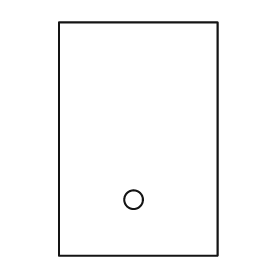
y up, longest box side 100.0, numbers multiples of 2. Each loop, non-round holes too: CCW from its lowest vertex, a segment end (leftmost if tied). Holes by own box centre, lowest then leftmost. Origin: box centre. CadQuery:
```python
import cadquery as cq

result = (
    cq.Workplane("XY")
    .moveTo(-34.0, -50.0)
    .lineTo(34.0, -50.0)
    .lineTo(34.0, 50.0)
    .lineTo(-34.0, 50.0)
    .close()
    .moveTo(-2.0, -26.0)
    .circle(4.0)
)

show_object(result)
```